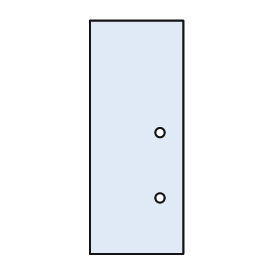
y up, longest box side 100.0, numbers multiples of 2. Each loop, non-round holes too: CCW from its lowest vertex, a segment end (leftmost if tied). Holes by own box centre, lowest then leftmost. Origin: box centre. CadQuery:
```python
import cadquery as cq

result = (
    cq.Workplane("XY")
    .moveTo(-20.0, -50.0)
    .lineTo(20.0, -50.0)
    .lineTo(20.0, 50.0)
    .lineTo(-20.0, 50.0)
    .close()
    .moveTo(10.0, -26.0)
    .circle(2.0)
    .moveTo(10.0, 2.0)
    .circle(2.0)
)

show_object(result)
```